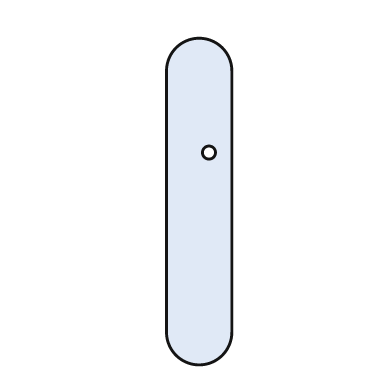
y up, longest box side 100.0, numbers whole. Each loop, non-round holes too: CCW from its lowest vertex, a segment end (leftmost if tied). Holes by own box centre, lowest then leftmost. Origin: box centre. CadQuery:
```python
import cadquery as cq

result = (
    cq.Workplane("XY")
    .moveTo(-10.0, -40.0)
    .threePointArc((0.0, -50.0), (10.0, -40.0))
    .lineTo(10.0, 40.0)
    .threePointArc((0.0, 50.0), (-10.0, 40.0))
    .close()
    .moveTo(3.0, 15.0)
    .circle(2.0)
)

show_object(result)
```